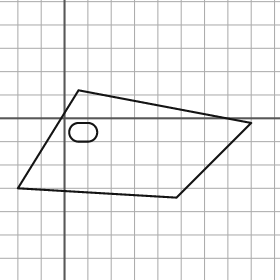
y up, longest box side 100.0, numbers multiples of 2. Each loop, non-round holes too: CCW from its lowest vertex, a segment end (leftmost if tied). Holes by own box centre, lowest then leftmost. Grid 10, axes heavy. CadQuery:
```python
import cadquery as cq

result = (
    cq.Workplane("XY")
    .moveTo(48.0, -34.0)
    .lineTo(80.0, -2.0)
    .lineTo(6.0, 12.0)
    .lineTo(-20.0, -30.0)
    .close()
    .moveTo(6.0, -10.0)
    .lineTo(10.0, -10.0)
    .threePointArc((14.0, -6.0), (10.0, -2.0))
    .lineTo(6.0, -2.0)
    .threePointArc((2.0, -6.0), (6.0, -10.0))
    .close()
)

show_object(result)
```